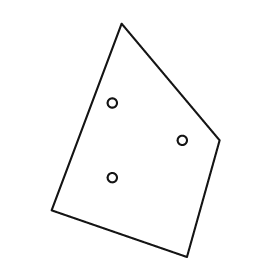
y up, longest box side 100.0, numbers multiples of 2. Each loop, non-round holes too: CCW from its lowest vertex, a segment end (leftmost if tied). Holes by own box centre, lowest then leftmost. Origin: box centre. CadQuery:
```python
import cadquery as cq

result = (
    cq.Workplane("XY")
    .moveTo(22.0, -50.0)
    .lineTo(36.0, 0.0)
    .lineTo(-6.0, 50.0)
    .lineTo(-36.0, -30.0)
    .close()
    .moveTo(-10.0, -16.0)
    .circle(2.0)
    .moveTo(20.0, 0.0)
    .circle(2.0)
    .moveTo(-10.0, 16.0)
    .circle(2.0)
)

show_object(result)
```